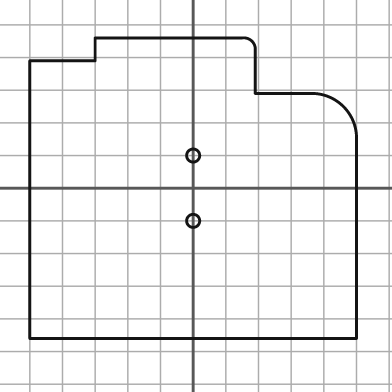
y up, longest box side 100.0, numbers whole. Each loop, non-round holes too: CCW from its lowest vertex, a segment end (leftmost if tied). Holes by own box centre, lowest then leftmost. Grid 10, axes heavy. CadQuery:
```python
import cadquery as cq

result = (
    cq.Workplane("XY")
    .moveTo(-50.0, -46.0)
    .lineTo(50.0, -46.0)
    .lineTo(50.0, 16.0)
    .threePointArc((46.0, 25.0), (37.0, 29.0))
    .lineTo(19.0, 29.0)
    .lineTo(19.0, 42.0)
    .threePointArc((18.0, 45.0), (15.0, 46.0))
    .lineTo(-30.0, 46.0)
    .lineTo(-30.0, 39.0)
    .lineTo(-50.0, 39.0)
    .close()
    .moveTo(0.0, -10.0)
    .circle(2.0)
    .moveTo(0.0, 10.0)
    .circle(2.0)
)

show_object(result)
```